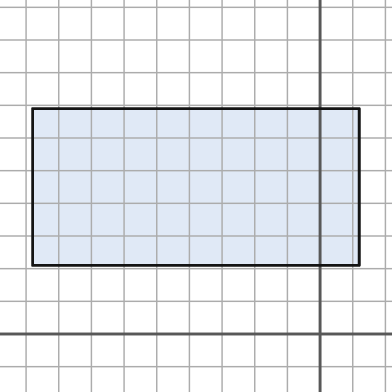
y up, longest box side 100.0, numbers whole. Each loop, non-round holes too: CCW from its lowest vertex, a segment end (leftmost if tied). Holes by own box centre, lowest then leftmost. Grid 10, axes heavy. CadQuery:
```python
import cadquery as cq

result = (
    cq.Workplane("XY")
    .moveTo(-88.0, 21.0)
    .lineTo(12.0, 21.0)
    .lineTo(12.0, 69.0)
    .lineTo(-88.0, 69.0)
    .close()
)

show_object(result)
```